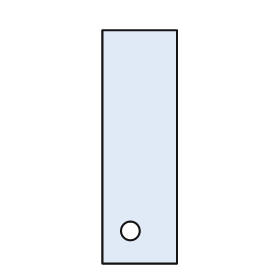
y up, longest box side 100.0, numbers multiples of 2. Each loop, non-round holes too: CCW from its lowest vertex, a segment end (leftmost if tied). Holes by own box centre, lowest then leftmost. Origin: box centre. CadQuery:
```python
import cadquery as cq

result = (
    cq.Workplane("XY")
    .moveTo(-16.0, -50.0)
    .lineTo(16.0, -50.0)
    .lineTo(16.0, 50.0)
    .lineTo(-16.0, 50.0)
    .close()
    .moveTo(-4.0, -36.0)
    .circle(4.0)
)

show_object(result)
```